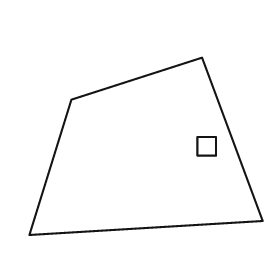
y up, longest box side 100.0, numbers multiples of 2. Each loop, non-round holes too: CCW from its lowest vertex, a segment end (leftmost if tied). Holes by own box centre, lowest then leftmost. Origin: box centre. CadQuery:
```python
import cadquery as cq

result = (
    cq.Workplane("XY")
    .moveTo(-50.0, -38.0)
    .lineTo(50.0, -32.0)
    .lineTo(24.0, 38.0)
    .lineTo(-32.0, 20.0)
    .close()
    .moveTo(22.0, -4.0)
    .lineTo(30.0, -4.0)
    .lineTo(30.0, 4.0)
    .lineTo(22.0, 4.0)
    .close()
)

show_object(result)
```